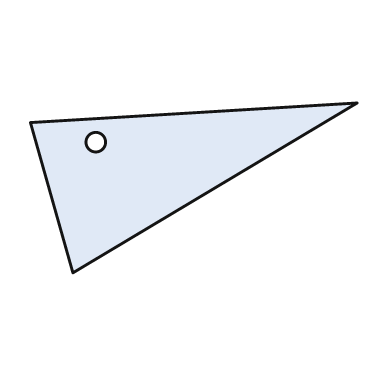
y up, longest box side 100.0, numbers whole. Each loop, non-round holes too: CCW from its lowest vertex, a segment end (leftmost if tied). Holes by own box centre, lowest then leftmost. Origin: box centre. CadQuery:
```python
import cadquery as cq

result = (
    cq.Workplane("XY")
    .moveTo(-37.0, -26.0)
    .lineTo(50.0, 26.0)
    .lineTo(-50.0, 20.0)
    .close()
    .moveTo(-30.0, 14.0)
    .circle(3.0)
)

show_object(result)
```